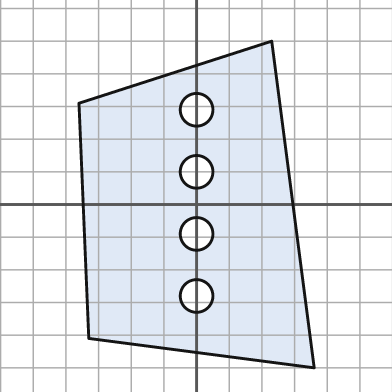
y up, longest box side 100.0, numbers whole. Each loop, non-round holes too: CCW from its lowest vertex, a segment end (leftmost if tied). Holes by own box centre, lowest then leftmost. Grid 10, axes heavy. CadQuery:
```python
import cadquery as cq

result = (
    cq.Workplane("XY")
    .moveTo(36.0, -50.0)
    .lineTo(23.0, 50.0)
    .lineTo(-36.0, 31.0)
    .lineTo(-33.0, -41.0)
    .close()
    .moveTo(0.0, -28.0)
    .circle(5.0)
    .moveTo(0.0, -9.0)
    .circle(5.0)
    .moveTo(0.0, 10.0)
    .circle(5.0)
    .moveTo(0.0, 29.0)
    .circle(5.0)
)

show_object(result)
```